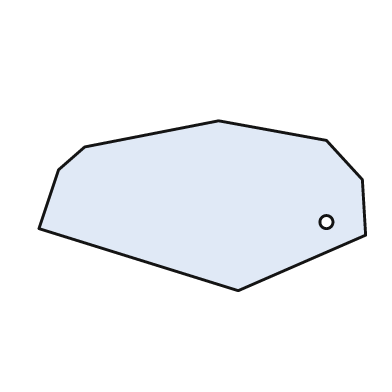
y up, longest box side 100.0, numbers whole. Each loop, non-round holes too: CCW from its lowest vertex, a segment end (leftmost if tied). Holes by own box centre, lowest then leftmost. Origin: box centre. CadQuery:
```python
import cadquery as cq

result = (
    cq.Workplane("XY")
    .moveTo(11.0, -26.0)
    .lineTo(50.0, -9.0)
    .lineTo(49.0, 8.0)
    .lineTo(38.0, 20.0)
    .lineTo(5.0, 26.0)
    .lineTo(-36.0, 18.0)
    .lineTo(-44.0, 11.0)
    .lineTo(-50.0, -7.0)
    .close()
    .moveTo(38.0, -5.0)
    .circle(2.0)
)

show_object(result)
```